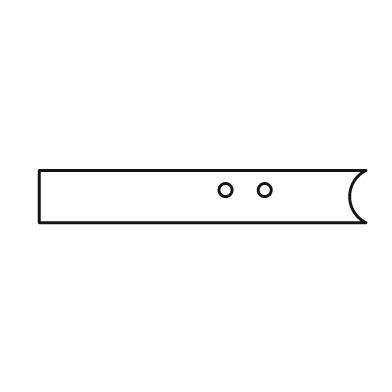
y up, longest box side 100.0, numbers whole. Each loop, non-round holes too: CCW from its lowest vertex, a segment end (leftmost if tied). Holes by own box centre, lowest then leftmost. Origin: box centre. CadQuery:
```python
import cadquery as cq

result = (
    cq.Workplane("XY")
    .moveTo(-50.0, -8.0)
    .lineTo(50.0, -8.0)
    .threePointArc((45.0, 0.0), (50.0, 8.0))
    .lineTo(-50.0, 8.0)
    .close()
    .moveTo(7.0, 2.0)
    .circle(2.0)
    .moveTo(19.0, 2.0)
    .circle(2.0)
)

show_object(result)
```